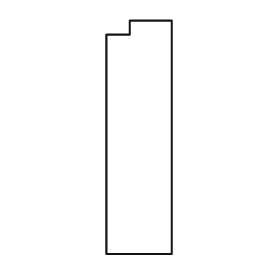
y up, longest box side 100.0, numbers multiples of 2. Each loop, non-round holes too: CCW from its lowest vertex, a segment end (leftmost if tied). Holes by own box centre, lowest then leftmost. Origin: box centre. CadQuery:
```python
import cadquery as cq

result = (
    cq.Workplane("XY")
    .moveTo(-14.0, -50.0)
    .lineTo(14.0, -50.0)
    .lineTo(14.0, 50.0)
    .lineTo(-4.0, 50.0)
    .lineTo(-4.0, 44.0)
    .lineTo(-14.0, 44.0)
    .close()
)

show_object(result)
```